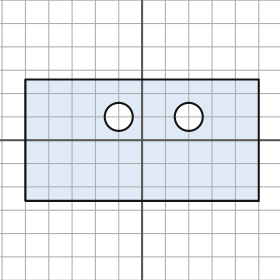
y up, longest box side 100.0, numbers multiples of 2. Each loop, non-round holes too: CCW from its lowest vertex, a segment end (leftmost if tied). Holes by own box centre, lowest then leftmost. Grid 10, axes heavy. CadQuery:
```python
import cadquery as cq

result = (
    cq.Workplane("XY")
    .moveTo(-50.0, -26.0)
    .lineTo(50.0, -26.0)
    .lineTo(50.0, 26.0)
    .lineTo(-50.0, 26.0)
    .close()
    .moveTo(-10.0, 10.0)
    .circle(6.0)
    .moveTo(20.0, 10.0)
    .circle(6.0)
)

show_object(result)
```